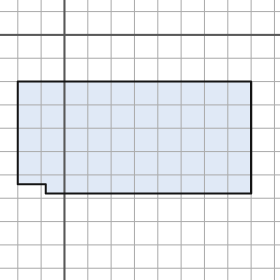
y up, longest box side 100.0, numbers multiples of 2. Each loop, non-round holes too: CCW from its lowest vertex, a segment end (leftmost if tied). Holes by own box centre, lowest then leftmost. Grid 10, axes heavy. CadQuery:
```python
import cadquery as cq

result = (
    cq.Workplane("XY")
    .moveTo(-8.0, -68.0)
    .lineTo(80.0, -68.0)
    .lineTo(80.0, -20.0)
    .lineTo(-20.0, -20.0)
    .lineTo(-20.0, -64.0)
    .lineTo(-8.0, -64.0)
    .close()
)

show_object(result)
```